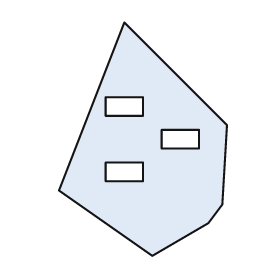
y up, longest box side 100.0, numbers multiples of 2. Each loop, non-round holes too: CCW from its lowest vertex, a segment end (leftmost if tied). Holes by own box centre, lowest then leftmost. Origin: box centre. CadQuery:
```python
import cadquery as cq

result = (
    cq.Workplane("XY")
    .moveTo(4.0, -50.0)
    .lineTo(28.0, -36.0)
    .lineTo(34.0, -28.0)
    .lineTo(36.0, 6.0)
    .lineTo(-8.0, 50.0)
    .lineTo(-36.0, -22.0)
    .close()
    .moveTo(-16.0, -18.0)
    .lineTo(0.0, -18.0)
    .lineTo(0.0, -10.0)
    .lineTo(-16.0, -10.0)
    .close()
    .moveTo(8.0, -4.0)
    .lineTo(24.0, -4.0)
    .lineTo(24.0, 4.0)
    .lineTo(8.0, 4.0)
    .close()
    .moveTo(-16.0, 10.0)
    .lineTo(0.0, 10.0)
    .lineTo(0.0, 18.0)
    .lineTo(-16.0, 18.0)
    .close()
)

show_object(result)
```